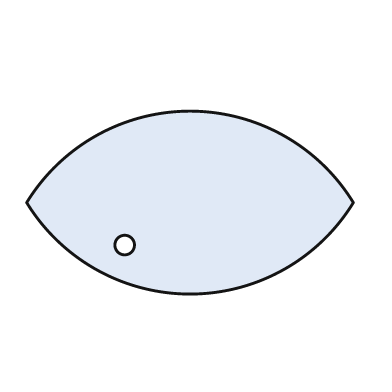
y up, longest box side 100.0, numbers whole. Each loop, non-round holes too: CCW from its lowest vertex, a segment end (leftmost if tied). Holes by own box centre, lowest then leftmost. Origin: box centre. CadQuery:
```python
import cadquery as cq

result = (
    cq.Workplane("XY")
    .moveTo(-50.0, 0.0)
    .threePointArc((0.0, -28.0), (50.0, 0.0))
    .threePointArc((0.0, 28.0), (-50.0, 0.0))
    .close()
    .moveTo(-20.0, -13.0)
    .circle(3.0)
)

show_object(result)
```